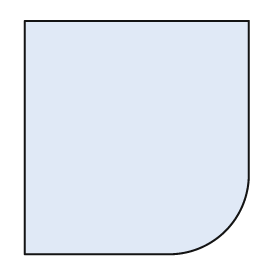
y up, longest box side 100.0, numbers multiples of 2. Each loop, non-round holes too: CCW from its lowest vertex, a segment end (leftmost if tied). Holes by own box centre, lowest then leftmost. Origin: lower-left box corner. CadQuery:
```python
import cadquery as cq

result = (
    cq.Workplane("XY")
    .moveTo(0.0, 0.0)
    .lineTo(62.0, 0.0)
    .threePointArc((86.0, 10.0), (96.0, 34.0))
    .lineTo(96.0, 100.0)
    .lineTo(0.0, 100.0)
    .close()
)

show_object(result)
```